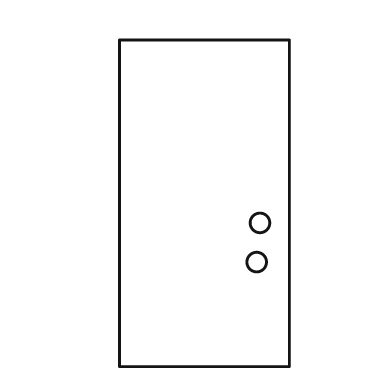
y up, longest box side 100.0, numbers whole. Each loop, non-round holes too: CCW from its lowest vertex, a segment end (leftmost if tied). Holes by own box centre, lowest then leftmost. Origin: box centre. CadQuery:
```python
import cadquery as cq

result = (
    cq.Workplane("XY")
    .moveTo(-26.0, -50.0)
    .lineTo(26.0, -50.0)
    .lineTo(26.0, 50.0)
    .lineTo(-26.0, 50.0)
    .close()
    .moveTo(16.0, -18.0)
    .circle(3.0)
    .moveTo(17.0, -6.0)
    .circle(3.0)
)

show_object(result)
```